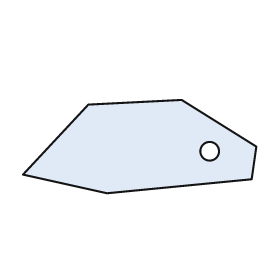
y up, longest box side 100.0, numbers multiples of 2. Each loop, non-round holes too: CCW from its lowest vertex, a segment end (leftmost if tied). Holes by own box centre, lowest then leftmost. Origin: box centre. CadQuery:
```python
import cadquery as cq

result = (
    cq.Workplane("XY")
    .moveTo(-14.0, -20.0)
    .lineTo(48.0, -14.0)
    .lineTo(50.0, 0.0)
    .lineTo(18.0, 20.0)
    .lineTo(-22.0, 18.0)
    .lineTo(-50.0, -12.0)
    .close()
    .moveTo(30.0, -2.0)
    .circle(4.0)
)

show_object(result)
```